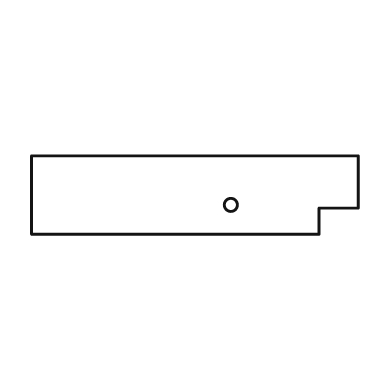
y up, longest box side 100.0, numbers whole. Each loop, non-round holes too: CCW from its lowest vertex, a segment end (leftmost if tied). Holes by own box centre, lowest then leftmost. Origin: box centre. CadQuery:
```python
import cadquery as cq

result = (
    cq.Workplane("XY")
    .moveTo(-50.0, -12.0)
    .lineTo(38.0, -12.0)
    .lineTo(38.0, -4.0)
    .lineTo(50.0, -4.0)
    .lineTo(50.0, 12.0)
    .lineTo(-50.0, 12.0)
    .close()
    .moveTo(11.0, -3.0)
    .circle(2.0)
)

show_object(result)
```